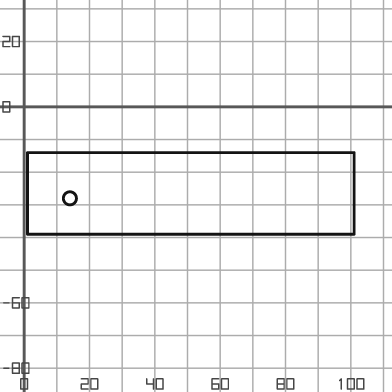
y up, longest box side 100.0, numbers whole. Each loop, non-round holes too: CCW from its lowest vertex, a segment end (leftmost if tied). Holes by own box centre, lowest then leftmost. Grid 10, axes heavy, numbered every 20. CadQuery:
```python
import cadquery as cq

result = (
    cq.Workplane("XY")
    .moveTo(1.0, -39.0)
    .lineTo(101.0, -39.0)
    .lineTo(101.0, -14.0)
    .lineTo(1.0, -14.0)
    .close()
    .moveTo(14.0, -28.0)
    .circle(2.0)
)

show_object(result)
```